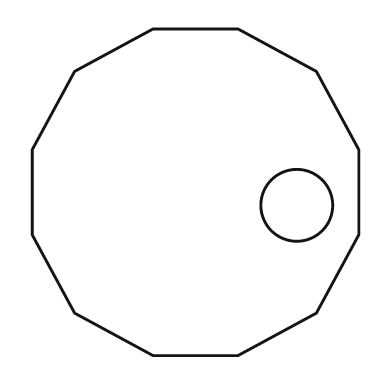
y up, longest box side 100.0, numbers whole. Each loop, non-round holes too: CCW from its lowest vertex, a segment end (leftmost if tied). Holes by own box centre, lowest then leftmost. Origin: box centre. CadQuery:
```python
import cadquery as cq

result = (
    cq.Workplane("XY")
    .moveTo(-13.0, -50.0)
    .lineTo(13.0, -50.0)
    .lineTo(37.0, -37.0)
    .lineTo(50.0, -13.0)
    .lineTo(50.0, 13.0)
    .lineTo(37.0, 37.0)
    .lineTo(13.0, 50.0)
    .lineTo(-13.0, 50.0)
    .lineTo(-37.0, 37.0)
    .lineTo(-50.0, 13.0)
    .lineTo(-50.0, -13.0)
    .lineTo(-37.0, -37.0)
    .close()
    .moveTo(31.0, -4.0)
    .circle(11.0)
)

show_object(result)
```